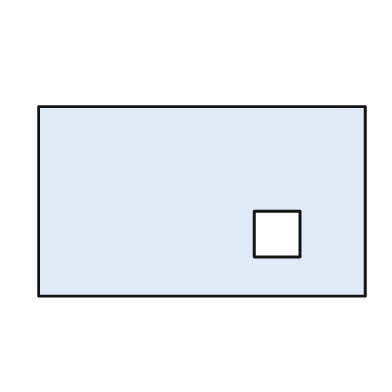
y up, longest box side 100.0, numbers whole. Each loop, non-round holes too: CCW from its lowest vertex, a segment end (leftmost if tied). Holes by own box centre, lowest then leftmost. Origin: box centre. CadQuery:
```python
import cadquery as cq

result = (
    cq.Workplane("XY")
    .moveTo(-50.0, -29.0)
    .lineTo(50.0, -29.0)
    .lineTo(50.0, 29.0)
    .lineTo(-50.0, 29.0)
    .close()
    .moveTo(16.0, -17.0)
    .lineTo(30.0, -17.0)
    .lineTo(30.0, -3.0)
    .lineTo(16.0, -3.0)
    .close()
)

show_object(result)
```